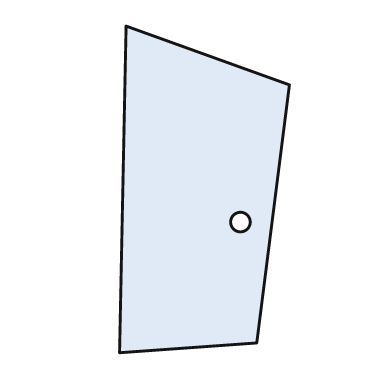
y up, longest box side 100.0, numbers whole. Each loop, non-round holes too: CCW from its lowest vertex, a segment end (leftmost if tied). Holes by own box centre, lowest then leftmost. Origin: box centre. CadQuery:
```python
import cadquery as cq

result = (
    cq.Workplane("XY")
    .moveTo(-26.0, -50.0)
    .lineTo(16.0, -47.0)
    .lineTo(26.0, 32.0)
    .lineTo(-24.0, 50.0)
    .close()
    .moveTo(11.0, -10.0)
    .circle(3.0)
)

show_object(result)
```